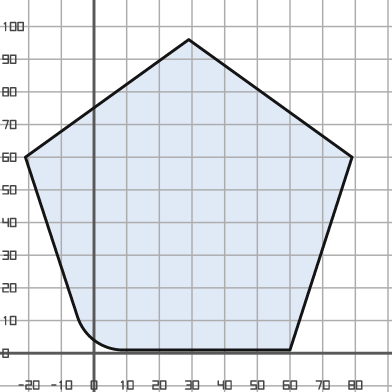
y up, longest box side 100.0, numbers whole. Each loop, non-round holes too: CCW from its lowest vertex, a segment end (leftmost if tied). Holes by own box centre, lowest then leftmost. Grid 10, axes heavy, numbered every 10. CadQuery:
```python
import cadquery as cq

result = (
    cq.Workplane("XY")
    .moveTo(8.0, 1.0)
    .lineTo(60.0, 1.0)
    .lineTo(79.0, 60.0)
    .lineTo(29.0, 96.0)
    .lineTo(-21.0, 60.0)
    .lineTo(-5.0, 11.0)
    .threePointArc((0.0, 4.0), (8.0, 1.0))
    .close()
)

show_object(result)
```